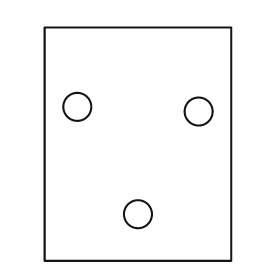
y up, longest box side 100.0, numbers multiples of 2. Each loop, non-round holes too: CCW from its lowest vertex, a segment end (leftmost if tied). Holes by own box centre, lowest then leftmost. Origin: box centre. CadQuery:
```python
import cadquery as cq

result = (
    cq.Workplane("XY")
    .moveTo(-40.0, -50.0)
    .lineTo(40.0, -50.0)
    .lineTo(40.0, 50.0)
    .lineTo(-40.0, 50.0)
    .close()
    .moveTo(0.0, -30.0)
    .circle(6.0)
    .moveTo(26.0, 14.0)
    .circle(6.0)
    .moveTo(-26.0, 16.0)
    .circle(6.0)
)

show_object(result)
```